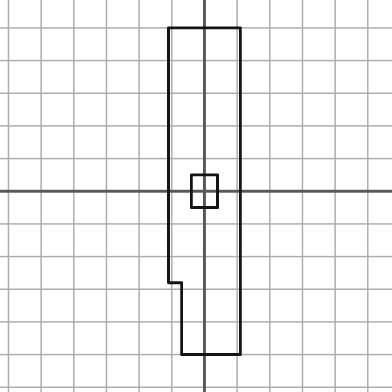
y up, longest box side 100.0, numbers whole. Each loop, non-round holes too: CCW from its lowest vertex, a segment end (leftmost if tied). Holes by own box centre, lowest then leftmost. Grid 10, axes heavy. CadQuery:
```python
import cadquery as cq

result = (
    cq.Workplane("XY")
    .moveTo(-7.0, -50.0)
    .lineTo(11.0, -50.0)
    .lineTo(11.0, 50.0)
    .lineTo(-11.0, 50.0)
    .lineTo(-11.0, -28.0)
    .lineTo(-7.0, -28.0)
    .close()
    .moveTo(-4.0, -5.0)
    .lineTo(4.0, -5.0)
    .lineTo(4.0, 5.0)
    .lineTo(-4.0, 5.0)
    .close()
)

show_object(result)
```